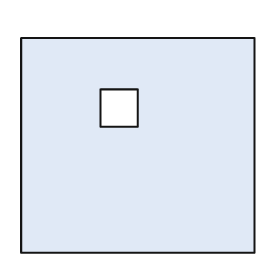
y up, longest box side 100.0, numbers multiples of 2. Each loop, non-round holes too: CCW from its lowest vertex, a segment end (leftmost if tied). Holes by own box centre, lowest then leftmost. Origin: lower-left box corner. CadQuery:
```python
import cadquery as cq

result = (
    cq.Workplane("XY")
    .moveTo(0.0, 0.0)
    .lineTo(100.0, 0.0)
    .lineTo(100.0, 92.0)
    .lineTo(0.0, 92.0)
    .close()
    .moveTo(34.0, 54.0)
    .lineTo(50.0, 54.0)
    .lineTo(50.0, 70.0)
    .lineTo(34.0, 70.0)
    .close()
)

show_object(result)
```